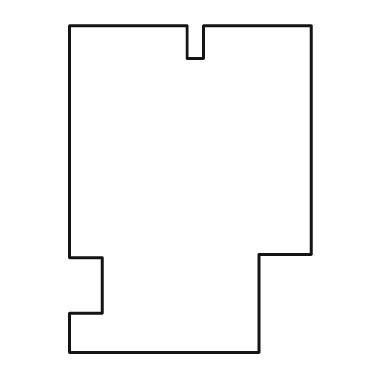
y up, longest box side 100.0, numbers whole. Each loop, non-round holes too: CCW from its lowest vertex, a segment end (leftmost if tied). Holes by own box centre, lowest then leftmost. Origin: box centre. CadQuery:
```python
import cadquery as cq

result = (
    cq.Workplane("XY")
    .moveTo(-37.0, -50.0)
    .lineTo(21.0, -50.0)
    .lineTo(21.0, -20.0)
    .lineTo(37.0, -20.0)
    .lineTo(37.0, 50.0)
    .lineTo(4.0, 50.0)
    .lineTo(4.0, 40.0)
    .lineTo(-1.0, 40.0)
    .lineTo(-1.0, 50.0)
    .lineTo(-37.0, 50.0)
    .lineTo(-37.0, -21.0)
    .lineTo(-27.0, -21.0)
    .lineTo(-27.0, -38.0)
    .lineTo(-37.0, -38.0)
    .close()
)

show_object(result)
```